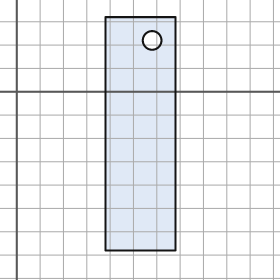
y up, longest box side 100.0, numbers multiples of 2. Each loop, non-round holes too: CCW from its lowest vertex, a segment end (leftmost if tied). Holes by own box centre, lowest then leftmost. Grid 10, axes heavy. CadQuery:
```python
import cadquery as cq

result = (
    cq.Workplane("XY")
    .moveTo(38.0, -68.0)
    .lineTo(68.0, -68.0)
    .lineTo(68.0, 32.0)
    .lineTo(38.0, 32.0)
    .close()
    .moveTo(58.0, 22.0)
    .circle(4.0)
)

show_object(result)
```